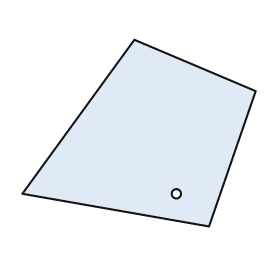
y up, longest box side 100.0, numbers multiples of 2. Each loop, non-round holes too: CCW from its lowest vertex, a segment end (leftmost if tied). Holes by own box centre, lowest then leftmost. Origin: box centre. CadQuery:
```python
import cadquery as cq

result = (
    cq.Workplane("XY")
    .moveTo(30.0, -40.0)
    .lineTo(50.0, 18.0)
    .lineTo(-2.0, 40.0)
    .lineTo(-50.0, -26.0)
    .close()
    .moveTo(16.0, -26.0)
    .circle(2.0)
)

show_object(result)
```